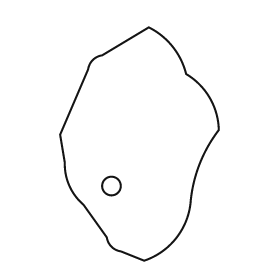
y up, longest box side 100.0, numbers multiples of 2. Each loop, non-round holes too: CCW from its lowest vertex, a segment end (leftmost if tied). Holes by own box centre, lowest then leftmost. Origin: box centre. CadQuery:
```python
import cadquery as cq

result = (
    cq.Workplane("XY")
    .moveTo(2.0, -50.0)
    .threePointArc((16.0, -40.0), (22.0, -24.0))
    .threePointArc((26.0, -8.0), (34.0, 6.0))
    .threePointArc((30.0, 20.0), (20.0, 30.0))
    .threePointArc((14.0, 42.0), (4.0, 50.0))
    .lineTo(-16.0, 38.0)
    .threePointArc((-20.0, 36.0), (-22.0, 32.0))
    .lineTo(-34.0, 4.0)
    .lineTo(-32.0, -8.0)
    .threePointArc((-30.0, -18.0), (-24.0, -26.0))
    .lineTo(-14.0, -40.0)
    .threePointArc((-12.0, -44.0), (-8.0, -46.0))
    .close()
    .moveTo(-12.0, -18.0)
    .circle(4.0)
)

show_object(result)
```